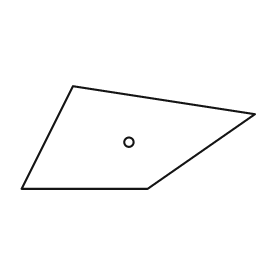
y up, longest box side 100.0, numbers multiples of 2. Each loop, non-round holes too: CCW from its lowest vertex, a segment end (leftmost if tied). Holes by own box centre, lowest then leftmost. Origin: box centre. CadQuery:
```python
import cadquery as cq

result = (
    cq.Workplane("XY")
    .moveTo(-50.0, -22.0)
    .lineTo(4.0, -22.0)
    .lineTo(50.0, 10.0)
    .lineTo(-28.0, 22.0)
    .close()
    .moveTo(-4.0, -2.0)
    .circle(2.0)
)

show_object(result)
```